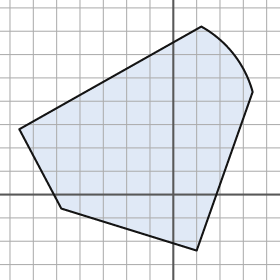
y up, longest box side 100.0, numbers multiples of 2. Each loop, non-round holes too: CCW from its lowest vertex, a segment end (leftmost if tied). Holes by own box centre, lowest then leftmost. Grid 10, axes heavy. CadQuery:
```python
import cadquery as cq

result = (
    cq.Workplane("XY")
    .moveTo(10.0, -24.0)
    .lineTo(34.0, 44.0)
    .threePointArc((26.0, 60.0), (12.0, 72.0))
    .lineTo(-66.0, 28.0)
    .lineTo(-48.0, -6.0)
    .close()
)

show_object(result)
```